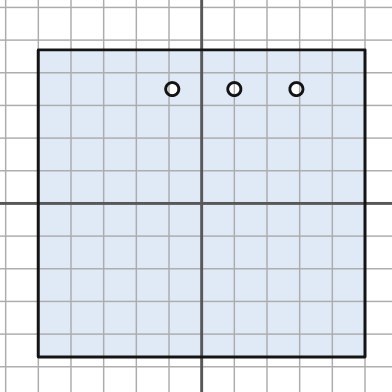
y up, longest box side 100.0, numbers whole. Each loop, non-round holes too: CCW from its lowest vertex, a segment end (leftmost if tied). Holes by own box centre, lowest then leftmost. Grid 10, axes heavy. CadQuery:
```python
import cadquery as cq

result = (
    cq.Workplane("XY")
    .moveTo(-50.0, -47.0)
    .lineTo(50.0, -47.0)
    .lineTo(50.0, 47.0)
    .lineTo(-50.0, 47.0)
    .close()
    .moveTo(-9.0, 35.0)
    .circle(2.0)
    .moveTo(10.0, 35.0)
    .circle(2.0)
    .moveTo(29.0, 35.0)
    .circle(2.0)
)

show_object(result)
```